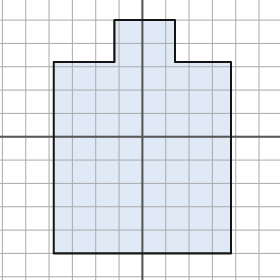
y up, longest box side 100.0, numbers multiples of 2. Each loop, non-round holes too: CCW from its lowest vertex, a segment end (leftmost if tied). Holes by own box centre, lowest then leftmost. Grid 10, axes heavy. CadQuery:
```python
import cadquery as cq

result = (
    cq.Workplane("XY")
    .moveTo(-38.0, -50.0)
    .lineTo(38.0, -50.0)
    .lineTo(38.0, 32.0)
    .lineTo(14.0, 32.0)
    .lineTo(14.0, 50.0)
    .lineTo(-12.0, 50.0)
    .lineTo(-12.0, 32.0)
    .lineTo(-38.0, 32.0)
    .close()
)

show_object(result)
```